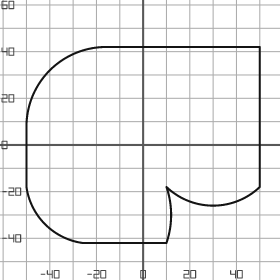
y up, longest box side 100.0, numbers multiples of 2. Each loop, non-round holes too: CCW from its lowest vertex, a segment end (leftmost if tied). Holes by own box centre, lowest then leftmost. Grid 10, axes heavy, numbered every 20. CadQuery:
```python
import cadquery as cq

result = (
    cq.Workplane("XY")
    .moveTo(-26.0, -42.0)
    .lineTo(10.0, -42.0)
    .threePointArc((12.0, -30.0), (10.0, -18.0))
    .threePointArc((30.0, -26.0), (50.0, -18.0))
    .lineTo(50.0, 42.0)
    .lineTo(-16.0, 42.0)
    .threePointArc((-40.0, 32.0), (-50.0, 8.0))
    .lineTo(-50.0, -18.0)
    .threePointArc((-42.0, -34.0), (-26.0, -42.0))
    .close()
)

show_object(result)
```